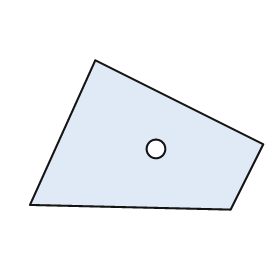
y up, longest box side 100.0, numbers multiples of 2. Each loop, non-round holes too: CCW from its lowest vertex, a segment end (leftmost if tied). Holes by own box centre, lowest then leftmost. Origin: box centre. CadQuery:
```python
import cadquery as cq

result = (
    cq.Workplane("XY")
    .moveTo(36.0, -32.0)
    .lineTo(50.0, -4.0)
    .lineTo(-22.0, 32.0)
    .lineTo(-50.0, -30.0)
    .close()
    .moveTo(4.0, -6.0)
    .circle(4.0)
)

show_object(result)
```